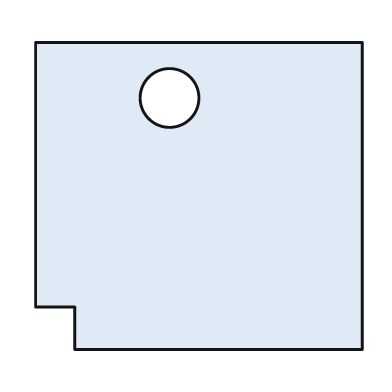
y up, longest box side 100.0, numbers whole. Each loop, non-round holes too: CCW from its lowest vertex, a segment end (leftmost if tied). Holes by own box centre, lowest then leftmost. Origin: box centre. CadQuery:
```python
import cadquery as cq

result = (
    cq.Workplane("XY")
    .moveTo(-38.0, -47.0)
    .lineTo(50.0, -47.0)
    .lineTo(50.0, 47.0)
    .lineTo(-50.0, 47.0)
    .lineTo(-50.0, -34.0)
    .lineTo(-38.0, -34.0)
    .close()
    .moveTo(-9.0, 30.0)
    .circle(9.0)
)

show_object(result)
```